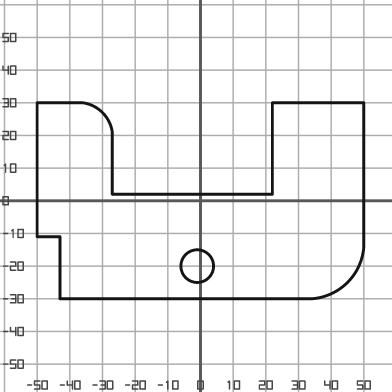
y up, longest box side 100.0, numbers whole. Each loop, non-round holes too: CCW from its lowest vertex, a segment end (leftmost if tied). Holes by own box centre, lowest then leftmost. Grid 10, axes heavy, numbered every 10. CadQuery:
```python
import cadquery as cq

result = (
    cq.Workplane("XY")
    .moveTo(-43.0, -30.0)
    .lineTo(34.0, -30.0)
    .threePointArc((45.0, -25.0), (50.0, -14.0))
    .lineTo(50.0, 30.0)
    .lineTo(22.0, 30.0)
    .lineTo(22.0, 2.0)
    .lineTo(-27.0, 2.0)
    .lineTo(-27.0, 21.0)
    .threePointArc((-30.0, 27.0), (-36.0, 30.0))
    .lineTo(-50.0, 30.0)
    .lineTo(-50.0, -11.0)
    .lineTo(-43.0, -11.0)
    .close()
    .moveTo(-1.0, -20.0)
    .circle(5.0)
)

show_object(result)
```